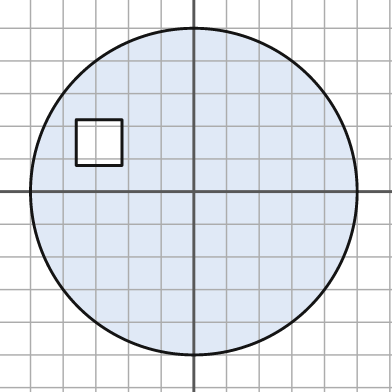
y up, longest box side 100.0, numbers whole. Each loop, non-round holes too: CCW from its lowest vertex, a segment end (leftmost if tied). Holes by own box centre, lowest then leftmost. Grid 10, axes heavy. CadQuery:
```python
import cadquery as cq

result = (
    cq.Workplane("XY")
    .moveTo(0.0, 0.0)
    .circle(50.0)
    .moveTo(-36.0, 8.0)
    .lineTo(-22.0, 8.0)
    .lineTo(-22.0, 22.0)
    .lineTo(-36.0, 22.0)
    .close()
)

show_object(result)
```